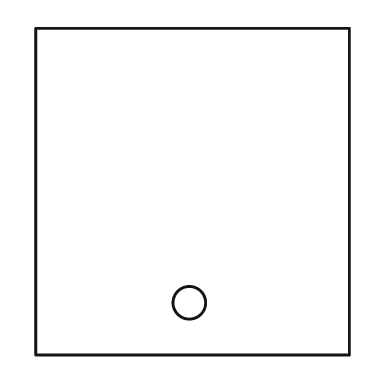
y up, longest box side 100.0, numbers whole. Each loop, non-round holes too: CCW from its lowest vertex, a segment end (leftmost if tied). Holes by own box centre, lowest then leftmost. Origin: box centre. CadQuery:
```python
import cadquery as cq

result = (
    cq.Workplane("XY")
    .moveTo(-48.0, -50.0)
    .lineTo(48.0, -50.0)
    .lineTo(48.0, 50.0)
    .lineTo(-48.0, 50.0)
    .close()
    .moveTo(-1.0, -34.0)
    .circle(5.0)
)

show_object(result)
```